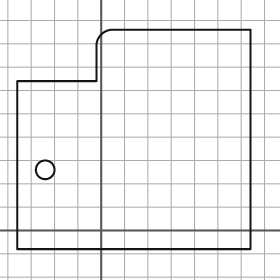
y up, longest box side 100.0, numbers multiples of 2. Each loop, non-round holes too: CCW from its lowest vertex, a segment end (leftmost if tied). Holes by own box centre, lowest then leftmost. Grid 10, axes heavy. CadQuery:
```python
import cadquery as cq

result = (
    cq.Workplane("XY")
    .moveTo(-36.0, -8.0)
    .lineTo(64.0, -8.0)
    .lineTo(64.0, 86.0)
    .lineTo(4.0, 86.0)
    .threePointArc((0.0, 84.0), (-2.0, 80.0))
    .lineTo(-2.0, 64.0)
    .lineTo(-36.0, 64.0)
    .close()
    .moveTo(-24.0, 26.0)
    .circle(4.0)
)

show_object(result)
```